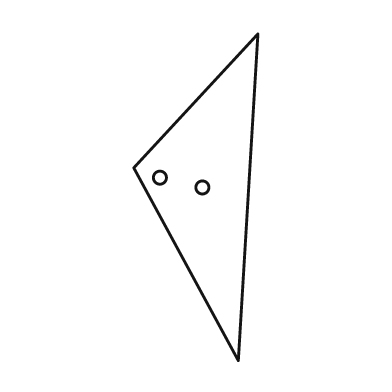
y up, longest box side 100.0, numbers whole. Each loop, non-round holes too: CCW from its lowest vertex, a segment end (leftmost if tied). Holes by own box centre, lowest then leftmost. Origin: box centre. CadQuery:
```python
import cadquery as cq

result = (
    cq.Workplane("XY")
    .moveTo(13.0, -50.0)
    .lineTo(19.0, 50.0)
    .lineTo(-19.0, 9.0)
    .close()
    .moveTo(2.0, 3.0)
    .circle(2.0)
    .moveTo(-11.0, 6.0)
    .circle(2.0)
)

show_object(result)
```